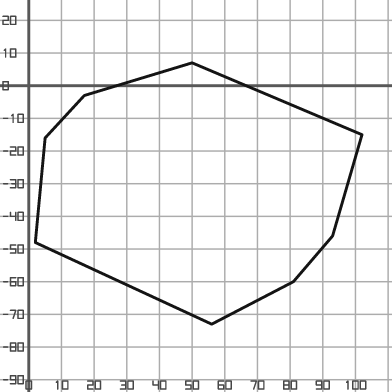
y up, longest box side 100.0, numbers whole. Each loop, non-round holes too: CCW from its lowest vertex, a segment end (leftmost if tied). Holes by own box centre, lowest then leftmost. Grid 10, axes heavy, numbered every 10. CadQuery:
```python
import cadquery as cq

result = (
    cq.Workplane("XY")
    .moveTo(56.0, -73.0)
    .lineTo(81.0, -60.0)
    .lineTo(93.0, -46.0)
    .lineTo(102.0, -15.0)
    .lineTo(50.0, 7.0)
    .lineTo(17.0, -3.0)
    .lineTo(5.0, -16.0)
    .lineTo(2.0, -48.0)
    .close()
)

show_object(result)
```